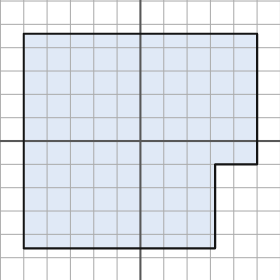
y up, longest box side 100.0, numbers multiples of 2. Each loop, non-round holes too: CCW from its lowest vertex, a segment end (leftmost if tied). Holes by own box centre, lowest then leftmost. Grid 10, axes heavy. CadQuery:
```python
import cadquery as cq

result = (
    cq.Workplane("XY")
    .moveTo(-50.0, -46.0)
    .lineTo(32.0, -46.0)
    .lineTo(32.0, -10.0)
    .lineTo(50.0, -10.0)
    .lineTo(50.0, 46.0)
    .lineTo(-50.0, 46.0)
    .close()
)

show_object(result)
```